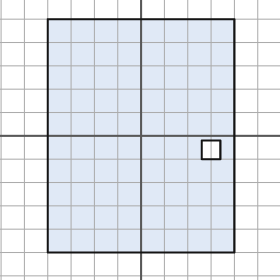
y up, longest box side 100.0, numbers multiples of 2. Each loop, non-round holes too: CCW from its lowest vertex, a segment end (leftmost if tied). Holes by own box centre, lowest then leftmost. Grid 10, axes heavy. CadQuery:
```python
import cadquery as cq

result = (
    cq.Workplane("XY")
    .moveTo(-40.0, -50.0)
    .lineTo(40.0, -50.0)
    .lineTo(40.0, 50.0)
    .lineTo(-40.0, 50.0)
    .close()
    .moveTo(26.0, -10.0)
    .lineTo(34.0, -10.0)
    .lineTo(34.0, -2.0)
    .lineTo(26.0, -2.0)
    .close()
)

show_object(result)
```